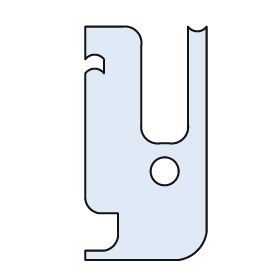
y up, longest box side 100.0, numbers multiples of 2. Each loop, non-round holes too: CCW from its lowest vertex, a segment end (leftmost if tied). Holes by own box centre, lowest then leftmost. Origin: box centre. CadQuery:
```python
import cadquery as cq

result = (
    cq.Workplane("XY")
    .moveTo(-26.0, -50.0)
    .lineTo(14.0, -50.0)
    .threePointArc((22.0, -46.0), (26.0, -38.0))
    .lineTo(26.0, 50.0)
    .threePointArc((22.0, 48.0), (18.0, 50.0))
    .lineTo(18.0, 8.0)
    .threePointArc((16.0, 2.0), (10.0, 0.0))
    .lineTo(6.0, 0.0)
    .threePointArc((0.0, 2.0), (-2.0, 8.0))
    .lineTo(-2.0, 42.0)
    .threePointArc((-4.0, 48.0), (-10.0, 50.0))
    .lineTo(-26.0, 50.0)
    .lineTo(-26.0, 36.0)
    .threePointArc((-22.0, 38.0), (-18.0, 36.0))
    .lineTo(-18.0, 30.0)
    .threePointArc((-22.0, 32.0), (-26.0, 30.0))
    .lineTo(-26.0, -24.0)
    .threePointArc((-24.0, -28.0), (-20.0, -30.0))
    .lineTo(-12.0, -30.0)
    .lineTo(-12.0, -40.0)
    .threePointArc((-14.0, -44.0), (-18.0, -46.0))
    .lineTo(-26.0, -46.0)
    .close()
    .moveTo(8.0, -12.0)
    .circle(6.0)
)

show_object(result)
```